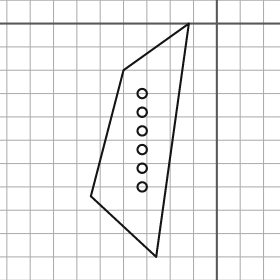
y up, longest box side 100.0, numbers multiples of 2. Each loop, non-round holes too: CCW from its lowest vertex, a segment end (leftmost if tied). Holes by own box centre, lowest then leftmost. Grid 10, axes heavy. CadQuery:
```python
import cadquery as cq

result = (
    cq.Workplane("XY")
    .moveTo(-26.0, -100.0)
    .lineTo(-12.0, 0.0)
    .lineTo(-40.0, -20.0)
    .lineTo(-54.0, -74.0)
    .close()
    .moveTo(-32.0, -70.0)
    .circle(2.0)
    .moveTo(-32.0, -62.0)
    .circle(2.0)
    .moveTo(-32.0, -54.0)
    .circle(2.0)
    .moveTo(-32.0, -46.0)
    .circle(2.0)
    .moveTo(-32.0, -38.0)
    .circle(2.0)
    .moveTo(-32.0, -30.0)
    .circle(2.0)
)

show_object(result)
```